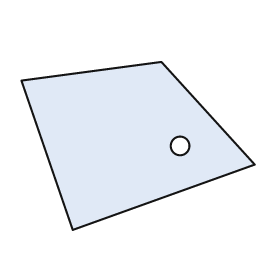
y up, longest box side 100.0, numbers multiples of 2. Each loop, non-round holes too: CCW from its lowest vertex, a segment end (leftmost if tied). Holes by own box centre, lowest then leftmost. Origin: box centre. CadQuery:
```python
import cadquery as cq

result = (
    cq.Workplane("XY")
    .moveTo(-28.0, -36.0)
    .lineTo(50.0, -8.0)
    .lineTo(10.0, 36.0)
    .lineTo(-50.0, 28.0)
    .close()
    .moveTo(18.0, 0.0)
    .circle(4.0)
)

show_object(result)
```